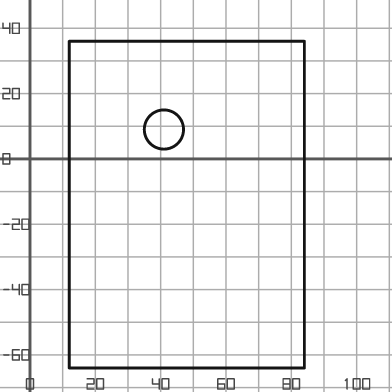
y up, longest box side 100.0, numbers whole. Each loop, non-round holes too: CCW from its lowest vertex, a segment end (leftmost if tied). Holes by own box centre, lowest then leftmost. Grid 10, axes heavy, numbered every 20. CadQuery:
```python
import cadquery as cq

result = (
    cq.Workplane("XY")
    .moveTo(12.0, -64.0)
    .lineTo(84.0, -64.0)
    .lineTo(84.0, 36.0)
    .lineTo(12.0, 36.0)
    .close()
    .moveTo(41.0, 9.0)
    .circle(6.0)
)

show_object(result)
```